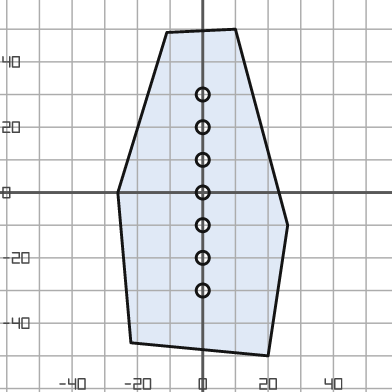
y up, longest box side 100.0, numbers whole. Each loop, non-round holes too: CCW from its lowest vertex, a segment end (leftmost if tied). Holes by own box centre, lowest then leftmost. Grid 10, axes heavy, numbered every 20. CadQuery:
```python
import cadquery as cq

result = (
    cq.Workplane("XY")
    .moveTo(20.0, -50.0)
    .lineTo(26.0, -10.0)
    .lineTo(10.0, 50.0)
    .lineTo(-11.0, 49.0)
    .lineTo(-26.0, 0.0)
    .lineTo(-22.0, -46.0)
    .close()
    .moveTo(0.0, -30.0)
    .circle(2.0)
    .moveTo(0.0, -20.0)
    .circle(2.0)
    .moveTo(0.0, -10.0)
    .circle(2.0)
    .moveTo(0.0, 0.0)
    .circle(2.0)
    .moveTo(0.0, 10.0)
    .circle(2.0)
    .moveTo(0.0, 20.0)
    .circle(2.0)
    .moveTo(0.0, 30.0)
    .circle(2.0)
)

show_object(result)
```